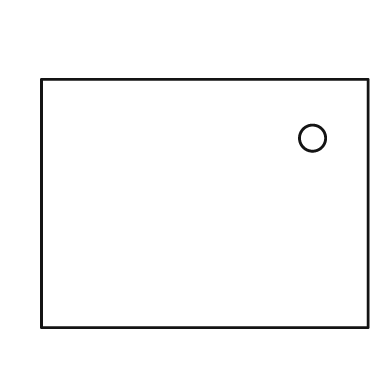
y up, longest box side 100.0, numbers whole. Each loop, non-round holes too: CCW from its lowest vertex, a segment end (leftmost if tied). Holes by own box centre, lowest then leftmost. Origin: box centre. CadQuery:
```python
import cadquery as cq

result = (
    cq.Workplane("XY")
    .moveTo(-50.0, -38.0)
    .lineTo(50.0, -38.0)
    .lineTo(50.0, 38.0)
    .lineTo(-50.0, 38.0)
    .close()
    .moveTo(33.0, 20.0)
    .circle(4.0)
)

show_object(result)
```